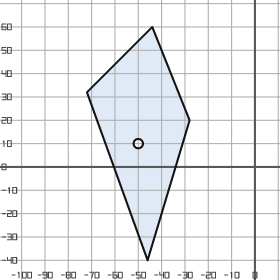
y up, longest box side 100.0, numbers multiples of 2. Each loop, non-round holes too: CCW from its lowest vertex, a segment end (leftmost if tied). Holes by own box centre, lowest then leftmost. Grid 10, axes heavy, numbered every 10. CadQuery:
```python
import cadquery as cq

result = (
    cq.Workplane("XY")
    .moveTo(-46.0, -40.0)
    .lineTo(-28.0, 20.0)
    .lineTo(-44.0, 60.0)
    .lineTo(-72.0, 32.0)
    .close()
    .moveTo(-50.0, 10.0)
    .circle(2.0)
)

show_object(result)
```